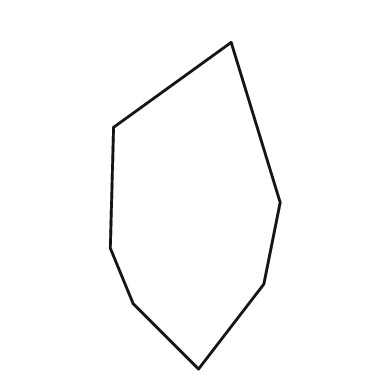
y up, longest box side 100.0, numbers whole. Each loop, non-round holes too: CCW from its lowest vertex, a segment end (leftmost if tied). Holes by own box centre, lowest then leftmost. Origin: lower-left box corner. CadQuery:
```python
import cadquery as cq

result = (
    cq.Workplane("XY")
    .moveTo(27.0, 0.0)
    .lineTo(47.0, 26.0)
    .lineTo(52.0, 51.0)
    .lineTo(37.0, 100.0)
    .lineTo(1.0, 74.0)
    .lineTo(0.0, 37.0)
    .lineTo(7.0, 20.0)
    .close()
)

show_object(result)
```